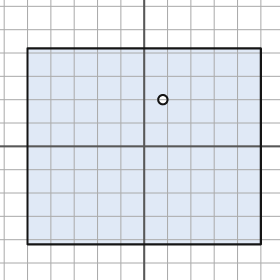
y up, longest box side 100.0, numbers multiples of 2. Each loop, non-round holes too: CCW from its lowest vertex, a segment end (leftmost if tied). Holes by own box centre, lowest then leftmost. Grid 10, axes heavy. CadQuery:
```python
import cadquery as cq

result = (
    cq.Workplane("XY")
    .moveTo(-50.0, -42.0)
    .lineTo(50.0, -42.0)
    .lineTo(50.0, 42.0)
    .lineTo(-50.0, 42.0)
    .close()
    .moveTo(8.0, 20.0)
    .circle(2.0)
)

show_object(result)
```